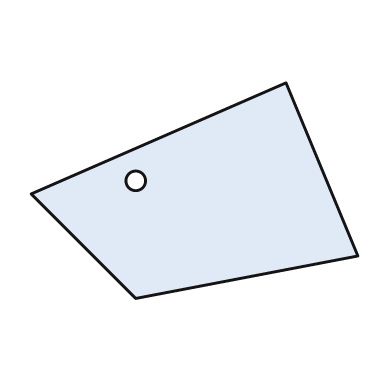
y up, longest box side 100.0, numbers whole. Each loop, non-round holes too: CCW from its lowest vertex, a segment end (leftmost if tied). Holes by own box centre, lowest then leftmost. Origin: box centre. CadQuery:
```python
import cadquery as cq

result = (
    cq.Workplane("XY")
    .moveTo(-18.0, -33.0)
    .lineTo(50.0, -20.0)
    .lineTo(28.0, 33.0)
    .lineTo(-50.0, -1.0)
    .close()
    .moveTo(-18.0, 3.0)
    .circle(3.0)
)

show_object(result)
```